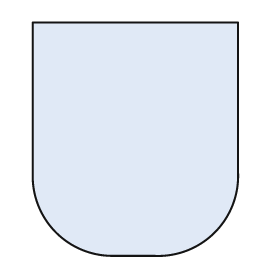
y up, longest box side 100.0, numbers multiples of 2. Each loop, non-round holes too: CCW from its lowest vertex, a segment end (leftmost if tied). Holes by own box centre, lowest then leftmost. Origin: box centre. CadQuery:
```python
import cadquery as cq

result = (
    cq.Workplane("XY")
    .moveTo(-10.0, -50.0)
    .lineTo(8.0, -50.0)
    .threePointArc((34.0, -40.0), (44.0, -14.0))
    .lineTo(44.0, 50.0)
    .lineTo(-44.0, 50.0)
    .lineTo(-44.0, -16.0)
    .threePointArc((-34.0, -40.0), (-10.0, -50.0))
    .close()
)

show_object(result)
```